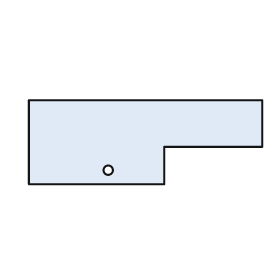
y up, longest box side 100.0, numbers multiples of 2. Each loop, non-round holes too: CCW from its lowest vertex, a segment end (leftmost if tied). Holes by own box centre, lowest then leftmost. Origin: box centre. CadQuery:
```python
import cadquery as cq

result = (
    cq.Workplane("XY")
    .moveTo(-50.0, -18.0)
    .lineTo(8.0, -18.0)
    .lineTo(8.0, -2.0)
    .lineTo(50.0, -2.0)
    .lineTo(50.0, 18.0)
    .lineTo(-50.0, 18.0)
    .close()
    .moveTo(-16.0, -12.0)
    .circle(2.0)
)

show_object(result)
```